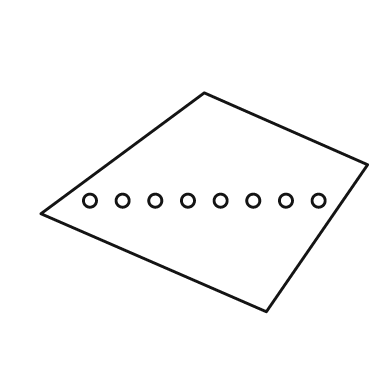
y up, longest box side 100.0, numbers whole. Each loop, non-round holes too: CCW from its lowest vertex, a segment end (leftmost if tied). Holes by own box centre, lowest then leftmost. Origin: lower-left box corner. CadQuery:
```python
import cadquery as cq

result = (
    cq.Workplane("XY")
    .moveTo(69.0, 0.0)
    .lineTo(100.0, 45.0)
    .lineTo(50.0, 67.0)
    .lineTo(0.0, 30.0)
    .close()
    .moveTo(15.0, 34.0)
    .circle(2.0)
    .moveTo(25.0, 34.0)
    .circle(2.0)
    .moveTo(35.0, 34.0)
    .circle(2.0)
    .moveTo(45.0, 34.0)
    .circle(2.0)
    .moveTo(55.0, 34.0)
    .circle(2.0)
    .moveTo(65.0, 34.0)
    .circle(2.0)
    .moveTo(75.0, 34.0)
    .circle(2.0)
    .moveTo(85.0, 34.0)
    .circle(2.0)
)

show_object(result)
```